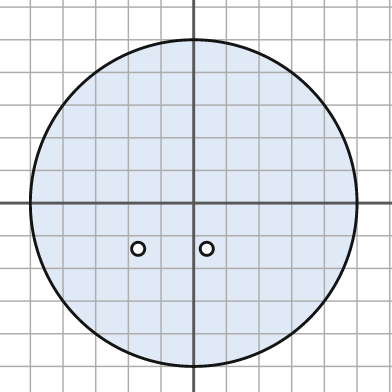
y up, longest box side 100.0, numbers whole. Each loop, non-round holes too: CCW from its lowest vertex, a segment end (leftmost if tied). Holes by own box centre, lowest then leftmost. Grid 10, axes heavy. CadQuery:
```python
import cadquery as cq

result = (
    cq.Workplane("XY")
    .moveTo(0.0, 0.0)
    .circle(50.0)
    .moveTo(-17.0, -14.0)
    .circle(2.0)
    .moveTo(4.0, -14.0)
    .circle(2.0)
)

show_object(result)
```